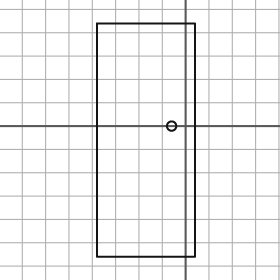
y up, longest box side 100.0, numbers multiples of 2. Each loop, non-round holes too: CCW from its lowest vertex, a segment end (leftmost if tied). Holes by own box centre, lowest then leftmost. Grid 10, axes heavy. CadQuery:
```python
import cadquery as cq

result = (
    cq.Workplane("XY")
    .moveTo(-38.0, -56.0)
    .lineTo(4.0, -56.0)
    .lineTo(4.0, 44.0)
    .lineTo(-38.0, 44.0)
    .close()
    .moveTo(-6.0, 0.0)
    .circle(2.0)
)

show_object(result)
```